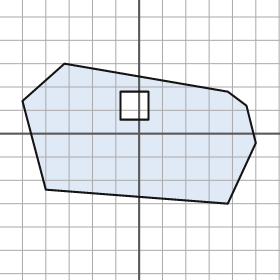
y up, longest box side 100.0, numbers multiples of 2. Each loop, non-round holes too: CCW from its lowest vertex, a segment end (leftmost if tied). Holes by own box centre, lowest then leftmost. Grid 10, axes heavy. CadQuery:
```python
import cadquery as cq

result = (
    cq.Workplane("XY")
    .moveTo(38.0, -30.0)
    .lineTo(50.0, -4.0)
    .lineTo(46.0, 12.0)
    .lineTo(38.0, 18.0)
    .lineTo(-32.0, 30.0)
    .lineTo(-50.0, 14.0)
    .lineTo(-40.0, -24.0)
    .close()
    .moveTo(-8.0, 6.0)
    .lineTo(4.0, 6.0)
    .lineTo(4.0, 18.0)
    .lineTo(-8.0, 18.0)
    .close()
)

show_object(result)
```